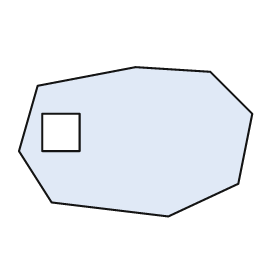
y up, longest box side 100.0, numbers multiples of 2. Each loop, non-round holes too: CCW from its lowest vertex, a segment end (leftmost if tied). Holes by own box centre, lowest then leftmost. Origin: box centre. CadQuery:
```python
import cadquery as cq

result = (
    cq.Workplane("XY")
    .moveTo(14.0, -32.0)
    .lineTo(44.0, -18.0)
    .lineTo(50.0, 12.0)
    .lineTo(32.0, 30.0)
    .lineTo(0.0, 32.0)
    .lineTo(-42.0, 24.0)
    .lineTo(-50.0, -4.0)
    .lineTo(-36.0, -26.0)
    .close()
    .moveTo(-40.0, -4.0)
    .lineTo(-24.0, -4.0)
    .lineTo(-24.0, 12.0)
    .lineTo(-40.0, 12.0)
    .close()
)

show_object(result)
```